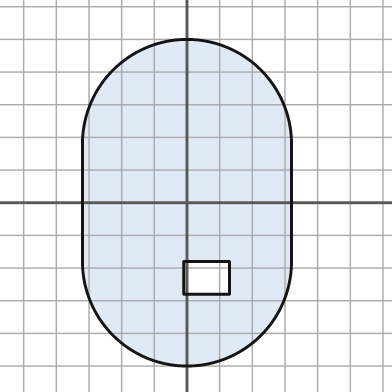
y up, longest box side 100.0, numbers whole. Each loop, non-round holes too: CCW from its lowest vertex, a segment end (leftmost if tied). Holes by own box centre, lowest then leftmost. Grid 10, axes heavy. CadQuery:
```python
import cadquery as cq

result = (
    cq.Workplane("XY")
    .moveTo(-32.0, -18.0)
    .threePointArc((0.0, -50.0), (32.0, -18.0))
    .lineTo(32.0, 18.0)
    .threePointArc((0.0, 50.0), (-32.0, 18.0))
    .close()
    .moveTo(-1.0, -28.0)
    .lineTo(13.0, -28.0)
    .lineTo(13.0, -18.0)
    .lineTo(-1.0, -18.0)
    .close()
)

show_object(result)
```